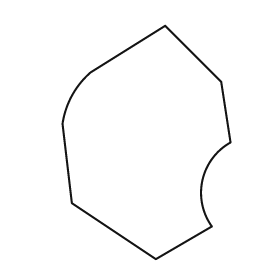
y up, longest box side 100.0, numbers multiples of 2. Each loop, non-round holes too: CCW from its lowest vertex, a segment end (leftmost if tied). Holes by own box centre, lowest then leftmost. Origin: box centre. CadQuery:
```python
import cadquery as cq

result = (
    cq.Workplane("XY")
    .moveTo(4.0, -50.0)
    .lineTo(28.0, -36.0)
    .threePointArc((24.0, -16.0), (36.0, 0.0))
    .lineTo(32.0, 26.0)
    .lineTo(8.0, 50.0)
    .lineTo(-24.0, 30.0)
    .threePointArc((-32.0, 20.0), (-36.0, 8.0))
    .lineTo(-32.0, -26.0)
    .close()
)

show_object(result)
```